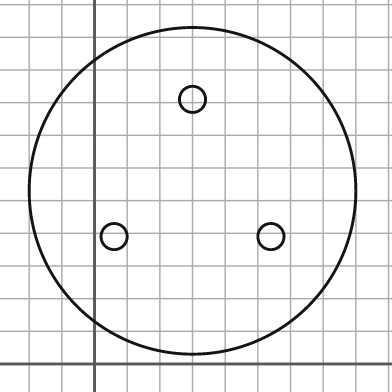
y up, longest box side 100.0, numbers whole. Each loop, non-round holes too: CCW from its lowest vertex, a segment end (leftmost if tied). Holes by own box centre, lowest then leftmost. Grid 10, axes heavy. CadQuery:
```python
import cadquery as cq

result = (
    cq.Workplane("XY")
    .moveTo(30.0, 53.0)
    .circle(50.0)
    .moveTo(6.0, 39.0)
    .circle(4.0)
    .moveTo(54.0, 39.0)
    .circle(4.0)
    .moveTo(30.0, 81.0)
    .circle(4.0)
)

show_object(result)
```